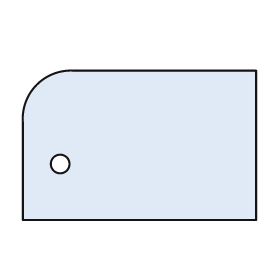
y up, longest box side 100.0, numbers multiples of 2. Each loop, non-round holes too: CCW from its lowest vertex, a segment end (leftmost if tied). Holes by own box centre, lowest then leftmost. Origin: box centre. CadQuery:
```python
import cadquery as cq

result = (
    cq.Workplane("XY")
    .moveTo(-50.0, -32.0)
    .lineTo(50.0, -32.0)
    .lineTo(50.0, 32.0)
    .lineTo(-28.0, 32.0)
    .threePointArc((-44.0, 26.0), (-50.0, 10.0))
    .close()
    .moveTo(-34.0, -8.0)
    .circle(4.0)
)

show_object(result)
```